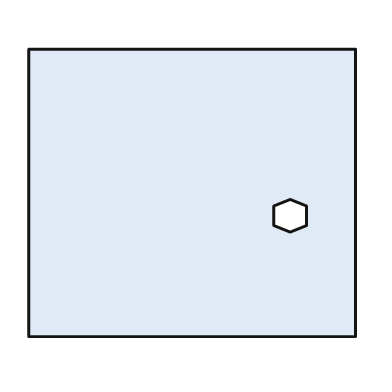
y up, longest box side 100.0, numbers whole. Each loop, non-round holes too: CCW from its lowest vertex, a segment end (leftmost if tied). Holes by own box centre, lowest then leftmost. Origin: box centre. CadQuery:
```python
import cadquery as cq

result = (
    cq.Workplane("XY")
    .moveTo(-50.0, -44.0)
    .lineTo(50.0, -44.0)
    .lineTo(50.0, 44.0)
    .lineTo(-50.0, 44.0)
    .close()
    .moveTo(30.0, -12.0)
    .lineTo(35.0, -10.0)
    .lineTo(35.0, -4.0)
    .lineTo(30.0, -2.0)
    .lineTo(25.0, -4.0)
    .lineTo(25.0, -10.0)
    .close()
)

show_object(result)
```